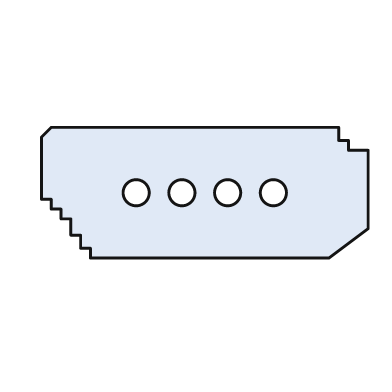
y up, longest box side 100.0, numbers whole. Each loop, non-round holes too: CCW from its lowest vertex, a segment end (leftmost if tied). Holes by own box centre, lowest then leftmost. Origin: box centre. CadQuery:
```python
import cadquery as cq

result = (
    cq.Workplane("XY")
    .moveTo(-35.0, -20.0)
    .lineTo(38.0, -20.0)
    .lineTo(50.0, -11.0)
    .lineTo(50.0, 13.0)
    .lineTo(44.0, 13.0)
    .lineTo(44.0, 16.0)
    .lineTo(41.0, 16.0)
    .lineTo(41.0, 20.0)
    .lineTo(-47.0, 20.0)
    .lineTo(-50.0, 17.0)
    .lineTo(-50.0, -2.0)
    .lineTo(-47.0, -2.0)
    .lineTo(-47.0, -5.0)
    .lineTo(-44.0, -5.0)
    .lineTo(-44.0, -8.0)
    .lineTo(-41.0, -8.0)
    .lineTo(-41.0, -13.0)
    .lineTo(-38.0, -13.0)
    .lineTo(-38.0, -17.0)
    .lineTo(-35.0, -17.0)
    .close()
    .moveTo(-21.0, 0.0)
    .circle(4.0)
    .moveTo(-7.0, 0.0)
    .circle(4.0)
    .moveTo(7.0, 0.0)
    .circle(4.0)
    .moveTo(21.0, 0.0)
    .circle(4.0)
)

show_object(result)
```